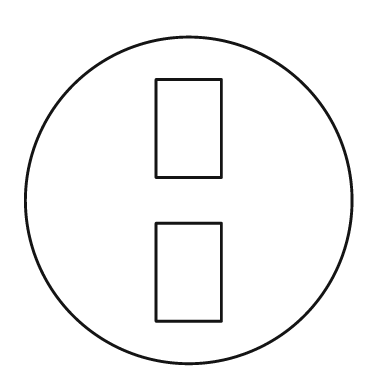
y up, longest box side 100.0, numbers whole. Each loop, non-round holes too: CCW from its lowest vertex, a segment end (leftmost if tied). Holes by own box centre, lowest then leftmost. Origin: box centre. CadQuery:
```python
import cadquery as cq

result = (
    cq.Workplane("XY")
    .moveTo(0.0, 0.0)
    .circle(50.0)
    .moveTo(-10.0, -37.0)
    .lineTo(10.0, -37.0)
    .lineTo(10.0, -7.0)
    .lineTo(-10.0, -7.0)
    .close()
    .moveTo(-10.0, 7.0)
    .lineTo(10.0, 7.0)
    .lineTo(10.0, 37.0)
    .lineTo(-10.0, 37.0)
    .close()
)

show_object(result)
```